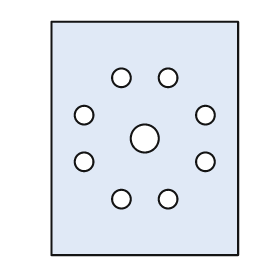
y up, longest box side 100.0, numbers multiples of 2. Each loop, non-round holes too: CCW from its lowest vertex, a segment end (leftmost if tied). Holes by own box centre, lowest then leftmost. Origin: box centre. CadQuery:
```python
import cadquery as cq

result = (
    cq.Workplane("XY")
    .moveTo(-40.0, -50.0)
    .lineTo(40.0, -50.0)
    .lineTo(40.0, 50.0)
    .lineTo(-40.0, 50.0)
    .close()
    .moveTo(-10.0, -26.0)
    .circle(4.0)
    .moveTo(10.0, -26.0)
    .circle(4.0)
    .moveTo(-26.0, -10.0)
    .circle(4.0)
    .moveTo(26.0, -10.0)
    .circle(4.0)
    .moveTo(0.0, 0.0)
    .circle(6.0)
    .moveTo(-26.0, 10.0)
    .circle(4.0)
    .moveTo(26.0, 10.0)
    .circle(4.0)
    .moveTo(-10.0, 26.0)
    .circle(4.0)
    .moveTo(10.0, 26.0)
    .circle(4.0)
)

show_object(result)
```